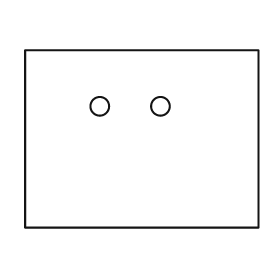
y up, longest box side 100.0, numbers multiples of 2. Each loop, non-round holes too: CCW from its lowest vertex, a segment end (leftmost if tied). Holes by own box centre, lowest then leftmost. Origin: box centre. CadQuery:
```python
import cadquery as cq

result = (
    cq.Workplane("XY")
    .moveTo(-50.0, -38.0)
    .lineTo(50.0, -38.0)
    .lineTo(50.0, 38.0)
    .lineTo(-50.0, 38.0)
    .close()
    .moveTo(-18.0, 14.0)
    .circle(4.0)
    .moveTo(8.0, 14.0)
    .circle(4.0)
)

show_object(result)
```